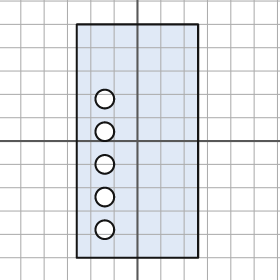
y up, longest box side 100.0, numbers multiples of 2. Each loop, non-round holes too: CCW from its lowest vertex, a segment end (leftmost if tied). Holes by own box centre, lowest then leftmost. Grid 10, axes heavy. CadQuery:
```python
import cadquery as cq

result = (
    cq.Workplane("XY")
    .moveTo(-26.0, -50.0)
    .lineTo(26.0, -50.0)
    .lineTo(26.0, 50.0)
    .lineTo(-26.0, 50.0)
    .close()
    .moveTo(-14.0, -38.0)
    .circle(4.0)
    .moveTo(-14.0, -24.0)
    .circle(4.0)
    .moveTo(-14.0, -10.0)
    .circle(4.0)
    .moveTo(-14.0, 4.0)
    .circle(4.0)
    .moveTo(-14.0, 18.0)
    .circle(4.0)
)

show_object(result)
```